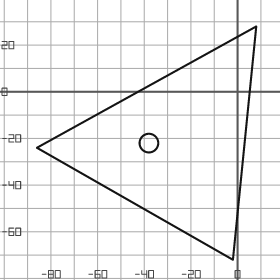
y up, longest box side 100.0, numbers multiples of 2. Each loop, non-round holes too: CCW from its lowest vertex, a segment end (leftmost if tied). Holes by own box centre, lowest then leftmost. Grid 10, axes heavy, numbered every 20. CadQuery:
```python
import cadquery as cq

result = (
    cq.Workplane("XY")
    .moveTo(-2.0, -72.0)
    .lineTo(8.0, 28.0)
    .lineTo(-86.0, -24.0)
    .close()
    .moveTo(-38.0, -22.0)
    .circle(4.0)
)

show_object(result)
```